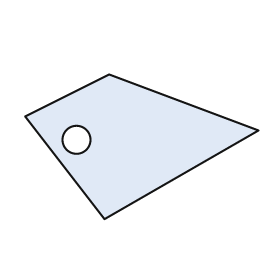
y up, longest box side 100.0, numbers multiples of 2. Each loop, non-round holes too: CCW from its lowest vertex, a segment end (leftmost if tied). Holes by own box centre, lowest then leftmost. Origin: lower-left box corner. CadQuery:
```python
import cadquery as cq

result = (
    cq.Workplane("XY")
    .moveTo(34.0, 0.0)
    .lineTo(100.0, 38.0)
    .lineTo(36.0, 62.0)
    .lineTo(0.0, 44.0)
    .close()
    .moveTo(22.0, 34.0)
    .circle(6.0)
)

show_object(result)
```